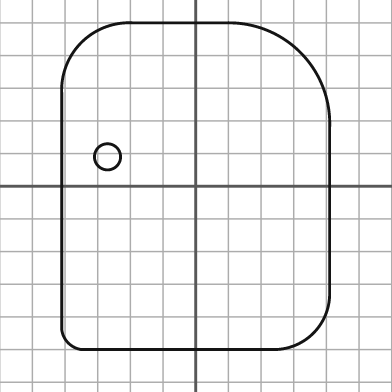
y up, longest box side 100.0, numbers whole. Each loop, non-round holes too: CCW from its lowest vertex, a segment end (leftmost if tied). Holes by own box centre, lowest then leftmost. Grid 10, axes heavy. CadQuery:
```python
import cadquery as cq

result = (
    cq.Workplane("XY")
    .moveTo(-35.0, -50.0)
    .lineTo(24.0, -50.0)
    .threePointArc((36.0, -45.0), (41.0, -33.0))
    .lineTo(41.0, 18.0)
    .threePointArc((32.0, 41.0), (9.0, 50.0))
    .lineTo(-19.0, 50.0)
    .threePointArc((-35.0, 44.0), (-41.0, 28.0))
    .lineTo(-41.0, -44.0)
    .threePointArc((-39.0, -48.0), (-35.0, -50.0))
    .close()
    .moveTo(-27.0, 9.0)
    .circle(4.0)
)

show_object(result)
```